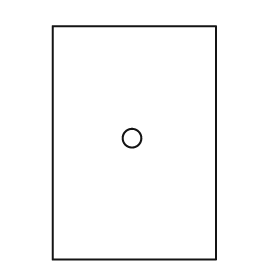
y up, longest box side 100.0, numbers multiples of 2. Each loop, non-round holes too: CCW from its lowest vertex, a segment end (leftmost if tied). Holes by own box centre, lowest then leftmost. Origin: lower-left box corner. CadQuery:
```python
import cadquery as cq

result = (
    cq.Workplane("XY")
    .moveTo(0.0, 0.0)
    .lineTo(70.0, 0.0)
    .lineTo(70.0, 100.0)
    .lineTo(0.0, 100.0)
    .close()
    .moveTo(34.0, 52.0)
    .circle(4.0)
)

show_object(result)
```